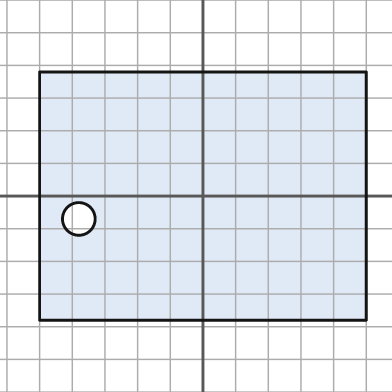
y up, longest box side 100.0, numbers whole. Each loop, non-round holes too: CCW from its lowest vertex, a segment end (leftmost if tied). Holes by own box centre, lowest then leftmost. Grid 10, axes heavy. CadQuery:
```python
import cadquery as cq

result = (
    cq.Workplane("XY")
    .moveTo(-50.0, -38.0)
    .lineTo(50.0, -38.0)
    .lineTo(50.0, 38.0)
    .lineTo(-50.0, 38.0)
    .close()
    .moveTo(-38.0, -7.0)
    .circle(5.0)
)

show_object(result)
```